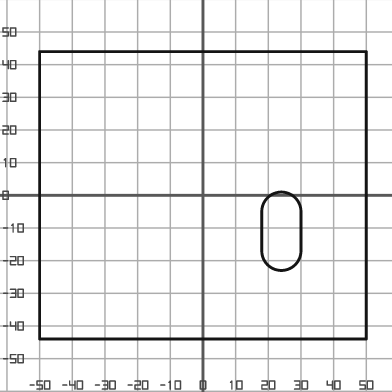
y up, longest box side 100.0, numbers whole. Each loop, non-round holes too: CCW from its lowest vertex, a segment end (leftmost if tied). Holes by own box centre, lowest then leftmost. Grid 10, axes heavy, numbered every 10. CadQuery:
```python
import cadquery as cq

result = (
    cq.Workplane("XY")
    .moveTo(-50.0, -44.0)
    .lineTo(50.0, -44.0)
    .lineTo(50.0, 44.0)
    .lineTo(-50.0, 44.0)
    .close()
    .moveTo(18.0, -17.0)
    .threePointArc((24.0, -23.0), (30.0, -17.0))
    .lineTo(30.0, -5.0)
    .threePointArc((24.0, 1.0), (18.0, -5.0))
    .close()
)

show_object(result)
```